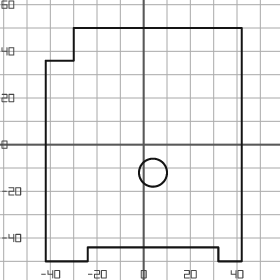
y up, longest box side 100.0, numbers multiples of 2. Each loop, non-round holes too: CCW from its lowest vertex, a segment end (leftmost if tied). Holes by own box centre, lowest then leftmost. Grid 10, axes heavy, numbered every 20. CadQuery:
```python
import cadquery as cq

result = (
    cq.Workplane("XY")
    .moveTo(-42.0, -50.0)
    .lineTo(-24.0, -50.0)
    .lineTo(-24.0, -44.0)
    .lineTo(32.0, -44.0)
    .lineTo(32.0, -50.0)
    .lineTo(42.0, -50.0)
    .lineTo(42.0, 50.0)
    .lineTo(-30.0, 50.0)
    .lineTo(-30.0, 36.0)
    .lineTo(-42.0, 36.0)
    .close()
    .moveTo(4.0, -12.0)
    .circle(6.0)
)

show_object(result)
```